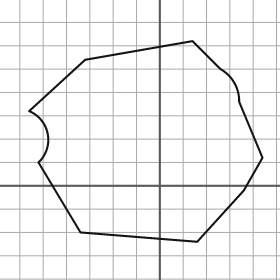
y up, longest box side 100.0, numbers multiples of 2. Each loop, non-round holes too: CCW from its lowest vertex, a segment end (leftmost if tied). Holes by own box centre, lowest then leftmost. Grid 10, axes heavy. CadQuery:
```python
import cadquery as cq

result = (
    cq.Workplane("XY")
    .moveTo(16.0, -24.0)
    .lineTo(36.0, -2.0)
    .lineTo(44.0, 12.0)
    .lineTo(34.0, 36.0)
    .threePointArc((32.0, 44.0), (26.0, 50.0))
    .lineTo(14.0, 62.0)
    .lineTo(-32.0, 54.0)
    .lineTo(-56.0, 32.0)
    .threePointArc((-48.0, 22.0), (-52.0, 10.0))
    .lineTo(-34.0, -20.0)
    .close()
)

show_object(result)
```